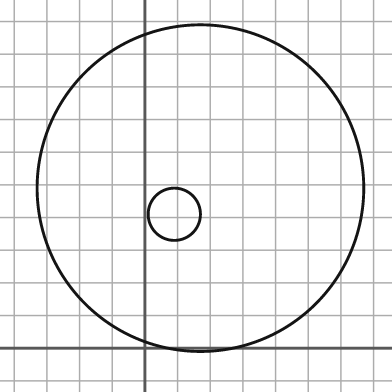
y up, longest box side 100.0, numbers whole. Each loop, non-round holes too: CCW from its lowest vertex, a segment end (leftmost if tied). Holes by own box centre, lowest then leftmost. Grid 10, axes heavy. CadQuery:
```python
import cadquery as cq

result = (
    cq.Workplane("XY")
    .moveTo(17.0, 49.0)
    .circle(50.0)
    .moveTo(9.0, 41.0)
    .circle(8.0)
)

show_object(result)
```